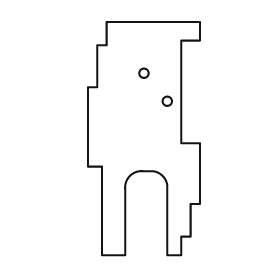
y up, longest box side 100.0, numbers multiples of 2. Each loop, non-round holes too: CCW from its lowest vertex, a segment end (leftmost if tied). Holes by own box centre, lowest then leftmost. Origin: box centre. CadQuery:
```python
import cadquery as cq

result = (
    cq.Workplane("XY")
    .moveTo(-18.0, -50.0)
    .lineTo(-8.0, -50.0)
    .lineTo(-8.0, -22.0)
    .threePointArc((-6.0, -16.0), (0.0, -14.0))
    .lineTo(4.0, -14.0)
    .threePointArc((8.0, -16.0), (10.0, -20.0))
    .lineTo(10.0, -50.0)
    .lineTo(16.0, -50.0)
    .lineTo(16.0, -42.0)
    .lineTo(20.0, -42.0)
    .lineTo(20.0, -28.0)
    .lineTo(24.0, -28.0)
    .lineTo(24.0, -2.0)
    .lineTo(16.0, -2.0)
    .lineTo(16.0, 42.0)
    .lineTo(24.0, 42.0)
    .lineTo(24.0, 50.0)
    .lineTo(-16.0, 50.0)
    .lineTo(-16.0, 40.0)
    .lineTo(-20.0, 40.0)
    .lineTo(-20.0, 22.0)
    .lineTo(-24.0, 22.0)
    .lineTo(-24.0, -12.0)
    .lineTo(-18.0, -12.0)
    .close()
    .moveTo(10.0, 16.0)
    .circle(2.0)
    .moveTo(0.0, 28.0)
    .circle(2.0)
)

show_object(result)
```